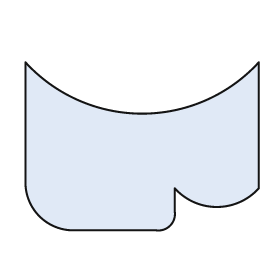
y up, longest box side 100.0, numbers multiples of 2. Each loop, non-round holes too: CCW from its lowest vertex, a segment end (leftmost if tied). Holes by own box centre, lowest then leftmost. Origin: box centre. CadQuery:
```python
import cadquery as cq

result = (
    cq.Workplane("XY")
    .moveTo(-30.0, -36.0)
    .lineTo(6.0, -36.0)
    .threePointArc((12.0, -34.0), (14.0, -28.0))
    .lineTo(14.0, -18.0)
    .threePointArc((32.0, -26.0), (50.0, -18.0))
    .lineTo(50.0, 36.0)
    .threePointArc((0.0, 14.0), (-50.0, 36.0))
    .lineTo(-50.0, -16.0)
    .threePointArc((-44.0, -30.0), (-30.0, -36.0))
    .close()
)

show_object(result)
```